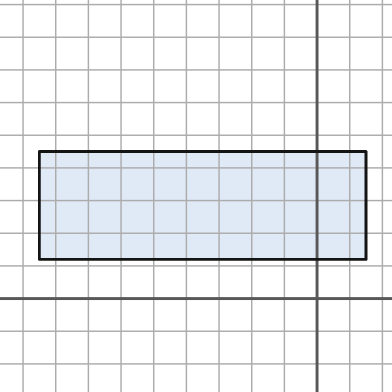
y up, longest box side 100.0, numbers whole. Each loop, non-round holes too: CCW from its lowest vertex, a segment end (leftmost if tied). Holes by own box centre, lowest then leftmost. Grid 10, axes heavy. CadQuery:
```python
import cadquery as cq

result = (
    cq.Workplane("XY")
    .moveTo(-85.0, 12.0)
    .lineTo(15.0, 12.0)
    .lineTo(15.0, 45.0)
    .lineTo(-85.0, 45.0)
    .close()
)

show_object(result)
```